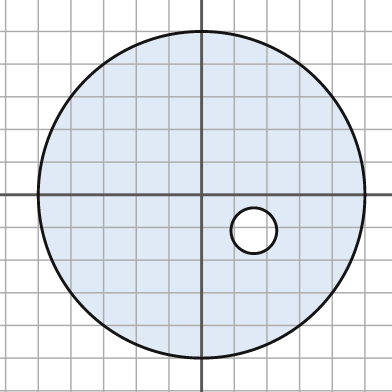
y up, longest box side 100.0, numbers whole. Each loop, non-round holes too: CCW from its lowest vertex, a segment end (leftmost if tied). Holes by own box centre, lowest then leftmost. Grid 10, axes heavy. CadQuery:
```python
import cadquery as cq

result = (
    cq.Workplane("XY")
    .moveTo(0.0, 0.0)
    .circle(50.0)
    .moveTo(16.0, -11.0)
    .circle(7.0)
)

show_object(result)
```